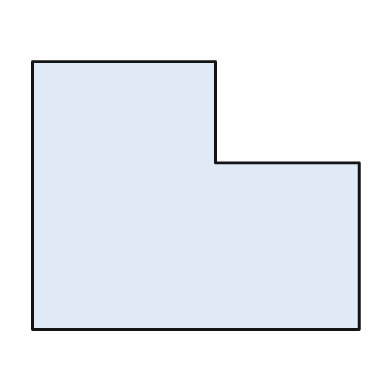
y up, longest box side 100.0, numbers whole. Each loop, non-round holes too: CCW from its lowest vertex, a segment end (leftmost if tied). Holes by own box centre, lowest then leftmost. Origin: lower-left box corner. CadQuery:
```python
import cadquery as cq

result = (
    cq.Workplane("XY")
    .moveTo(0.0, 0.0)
    .lineTo(100.0, 0.0)
    .lineTo(100.0, 51.0)
    .lineTo(56.0, 51.0)
    .lineTo(56.0, 82.0)
    .lineTo(0.0, 82.0)
    .close()
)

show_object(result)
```